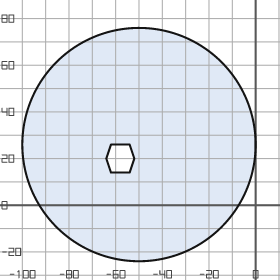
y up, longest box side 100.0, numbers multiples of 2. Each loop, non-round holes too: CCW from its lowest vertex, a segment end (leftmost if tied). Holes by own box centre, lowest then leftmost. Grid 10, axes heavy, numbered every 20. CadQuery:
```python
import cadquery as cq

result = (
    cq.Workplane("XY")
    .moveTo(-50.0, 26.0)
    .circle(50.0)
    .moveTo(-62.0, 14.0)
    .lineTo(-54.0, 14.0)
    .lineTo(-52.0, 20.0)
    .lineTo(-54.0, 26.0)
    .lineTo(-62.0, 26.0)
    .lineTo(-64.0, 20.0)
    .close()
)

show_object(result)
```